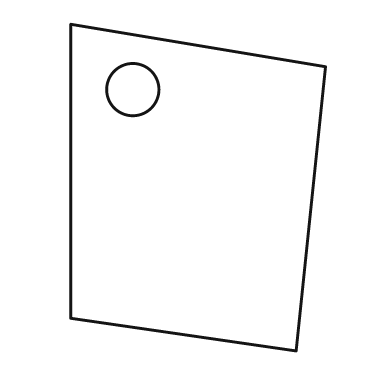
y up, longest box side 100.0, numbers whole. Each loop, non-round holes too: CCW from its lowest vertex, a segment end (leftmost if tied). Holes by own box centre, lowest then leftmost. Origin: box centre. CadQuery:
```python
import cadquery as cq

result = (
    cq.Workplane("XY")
    .moveTo(30.0, -50.0)
    .lineTo(39.0, 37.0)
    .lineTo(-39.0, 50.0)
    .lineTo(-39.0, -40.0)
    .close()
    .moveTo(-20.0, 30.0)
    .circle(8.0)
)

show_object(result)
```